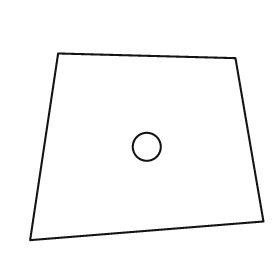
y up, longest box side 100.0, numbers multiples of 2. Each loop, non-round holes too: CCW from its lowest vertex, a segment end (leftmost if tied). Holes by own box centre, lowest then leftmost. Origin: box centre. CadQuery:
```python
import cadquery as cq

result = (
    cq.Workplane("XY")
    .moveTo(-50.0, -40.0)
    .lineTo(50.0, -32.0)
    .lineTo(38.0, 38.0)
    .lineTo(-38.0, 40.0)
    .close()
    .moveTo(0.0, 0.0)
    .circle(6.0)
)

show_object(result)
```